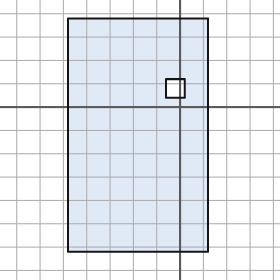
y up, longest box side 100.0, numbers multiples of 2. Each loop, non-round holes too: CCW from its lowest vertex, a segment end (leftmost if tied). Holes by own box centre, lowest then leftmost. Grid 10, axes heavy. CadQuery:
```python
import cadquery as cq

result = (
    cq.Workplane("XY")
    .moveTo(-48.0, -62.0)
    .lineTo(12.0, -62.0)
    .lineTo(12.0, 38.0)
    .lineTo(-48.0, 38.0)
    .close()
    .moveTo(-6.0, 4.0)
    .lineTo(2.0, 4.0)
    .lineTo(2.0, 12.0)
    .lineTo(-6.0, 12.0)
    .close()
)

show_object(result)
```